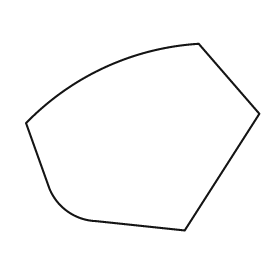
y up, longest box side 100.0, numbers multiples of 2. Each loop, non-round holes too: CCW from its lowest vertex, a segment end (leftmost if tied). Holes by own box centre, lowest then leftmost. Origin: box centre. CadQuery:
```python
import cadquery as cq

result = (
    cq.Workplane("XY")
    .moveTo(18.0, -40.0)
    .lineTo(50.0, 10.0)
    .lineTo(24.0, 40.0)
    .threePointArc((-16.0, 30.0), (-50.0, 6.0))
    .lineTo(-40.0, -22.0)
    .threePointArc((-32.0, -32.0), (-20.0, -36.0))
    .close()
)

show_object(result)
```